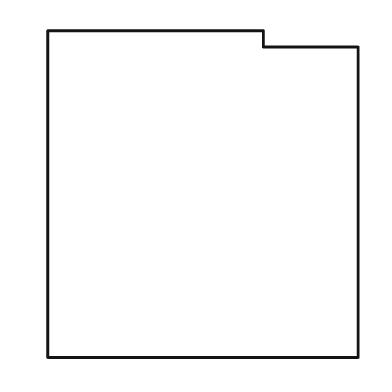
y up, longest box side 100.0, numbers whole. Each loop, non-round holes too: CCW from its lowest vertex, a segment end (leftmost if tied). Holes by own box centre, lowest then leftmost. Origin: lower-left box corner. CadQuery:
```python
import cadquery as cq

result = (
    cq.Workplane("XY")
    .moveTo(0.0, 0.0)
    .lineTo(95.0, 0.0)
    .lineTo(95.0, 95.0)
    .lineTo(66.0, 95.0)
    .lineTo(66.0, 100.0)
    .lineTo(0.0, 100.0)
    .close()
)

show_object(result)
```